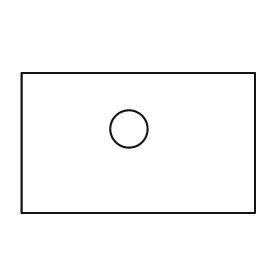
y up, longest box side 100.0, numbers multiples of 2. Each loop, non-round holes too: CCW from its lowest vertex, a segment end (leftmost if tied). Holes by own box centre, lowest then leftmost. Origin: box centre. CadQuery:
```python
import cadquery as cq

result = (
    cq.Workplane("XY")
    .moveTo(-50.0, -30.0)
    .lineTo(50.0, -30.0)
    .lineTo(50.0, 30.0)
    .lineTo(-50.0, 30.0)
    .close()
    .moveTo(-4.0, 6.0)
    .circle(8.0)
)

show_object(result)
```